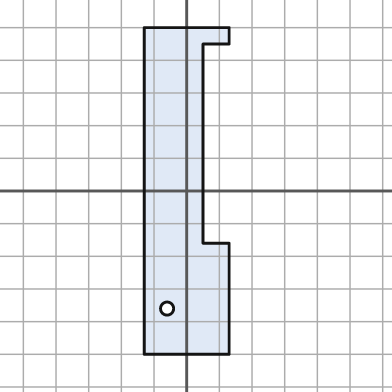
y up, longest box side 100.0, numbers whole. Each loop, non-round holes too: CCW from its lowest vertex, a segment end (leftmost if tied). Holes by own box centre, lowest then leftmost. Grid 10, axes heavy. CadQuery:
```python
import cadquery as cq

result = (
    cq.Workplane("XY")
    .moveTo(-13.0, -50.0)
    .lineTo(13.0, -50.0)
    .lineTo(13.0, -16.0)
    .lineTo(5.0, -16.0)
    .lineTo(5.0, 45.0)
    .lineTo(13.0, 45.0)
    .lineTo(13.0, 50.0)
    .lineTo(-13.0, 50.0)
    .close()
    .moveTo(-6.0, -36.0)
    .circle(2.0)
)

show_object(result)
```